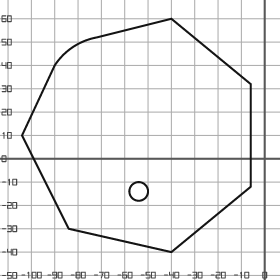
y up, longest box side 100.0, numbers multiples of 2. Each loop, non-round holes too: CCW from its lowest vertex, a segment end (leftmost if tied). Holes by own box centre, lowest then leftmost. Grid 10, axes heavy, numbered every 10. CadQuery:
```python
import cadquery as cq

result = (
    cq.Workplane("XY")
    .moveTo(-40.0, -40.0)
    .lineTo(-6.0, -12.0)
    .lineTo(-6.0, 32.0)
    .lineTo(-40.0, 60.0)
    .lineTo(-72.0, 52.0)
    .threePointArc((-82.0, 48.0), (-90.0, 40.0))
    .lineTo(-104.0, 10.0)
    .lineTo(-84.0, -30.0)
    .close()
    .moveTo(-54.0, -14.0)
    .circle(4.0)
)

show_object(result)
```